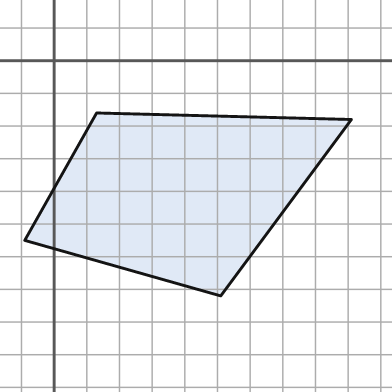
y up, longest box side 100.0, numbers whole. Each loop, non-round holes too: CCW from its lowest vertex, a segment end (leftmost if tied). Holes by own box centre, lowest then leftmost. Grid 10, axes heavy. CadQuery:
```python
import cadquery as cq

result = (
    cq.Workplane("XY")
    .moveTo(51.0, -72.0)
    .lineTo(91.0, -18.0)
    .lineTo(13.0, -16.0)
    .lineTo(-9.0, -55.0)
    .close()
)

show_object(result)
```